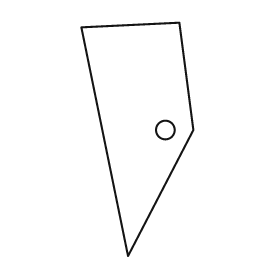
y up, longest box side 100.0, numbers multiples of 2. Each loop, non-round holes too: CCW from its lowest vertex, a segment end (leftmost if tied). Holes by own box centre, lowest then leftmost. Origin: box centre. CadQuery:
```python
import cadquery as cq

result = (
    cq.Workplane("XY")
    .moveTo(-4.0, -50.0)
    .lineTo(24.0, 4.0)
    .lineTo(18.0, 50.0)
    .lineTo(-24.0, 48.0)
    .close()
    .moveTo(12.0, 4.0)
    .circle(4.0)
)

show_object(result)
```